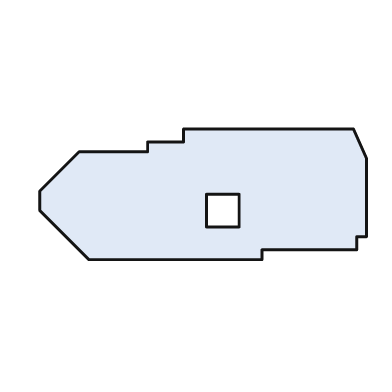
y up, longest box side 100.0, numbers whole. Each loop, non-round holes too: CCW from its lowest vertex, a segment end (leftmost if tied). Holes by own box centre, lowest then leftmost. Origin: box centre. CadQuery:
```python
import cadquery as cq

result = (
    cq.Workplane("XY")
    .moveTo(-35.0, -20.0)
    .lineTo(18.0, -20.0)
    .lineTo(18.0, -17.0)
    .lineTo(47.0, -17.0)
    .lineTo(47.0, -13.0)
    .lineTo(50.0, -13.0)
    .lineTo(50.0, 11.0)
    .lineTo(46.0, 20.0)
    .lineTo(-6.0, 20.0)
    .lineTo(-6.0, 16.0)
    .lineTo(-17.0, 16.0)
    .lineTo(-17.0, 13.0)
    .lineTo(-38.0, 13.0)
    .lineTo(-50.0, 1.0)
    .lineTo(-50.0, -5.0)
    .close()
    .moveTo(1.0, -10.0)
    .lineTo(11.0, -10.0)
    .lineTo(11.0, 0.0)
    .lineTo(1.0, 0.0)
    .close()
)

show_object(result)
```